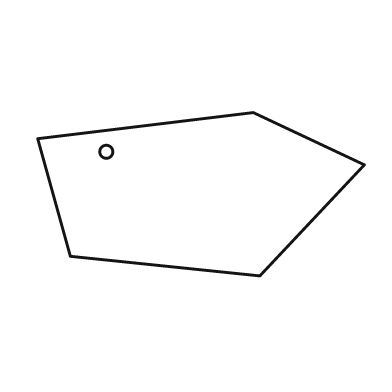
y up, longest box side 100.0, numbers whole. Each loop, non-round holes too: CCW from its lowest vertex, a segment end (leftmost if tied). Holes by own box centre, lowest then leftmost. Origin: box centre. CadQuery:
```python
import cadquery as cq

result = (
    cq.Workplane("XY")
    .moveTo(18.0, -25.0)
    .lineTo(50.0, 9.0)
    .lineTo(16.0, 25.0)
    .lineTo(-50.0, 17.0)
    .lineTo(-40.0, -19.0)
    .close()
    .moveTo(-29.0, 13.0)
    .circle(2.0)
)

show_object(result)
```